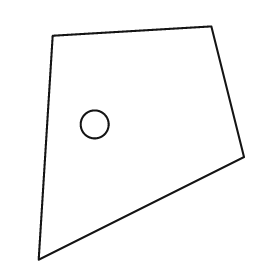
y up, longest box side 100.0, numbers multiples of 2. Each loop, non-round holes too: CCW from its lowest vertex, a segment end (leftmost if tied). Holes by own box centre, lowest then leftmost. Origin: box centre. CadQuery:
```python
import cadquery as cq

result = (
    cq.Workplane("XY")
    .moveTo(-44.0, -50.0)
    .lineTo(44.0, -6.0)
    .lineTo(30.0, 50.0)
    .lineTo(-38.0, 46.0)
    .close()
    .moveTo(-20.0, 8.0)
    .circle(6.0)
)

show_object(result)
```